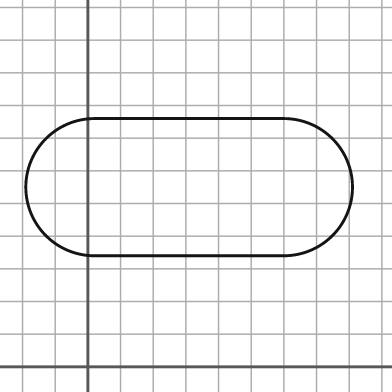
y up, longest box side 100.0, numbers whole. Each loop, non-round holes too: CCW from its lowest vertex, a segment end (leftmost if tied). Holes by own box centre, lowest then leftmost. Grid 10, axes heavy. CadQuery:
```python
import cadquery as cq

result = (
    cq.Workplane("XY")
    .moveTo(2.0, 34.0)
    .lineTo(60.0, 34.0)
    .threePointArc((81.0, 55.0), (60.0, 76.0))
    .lineTo(2.0, 76.0)
    .threePointArc((-19.0, 55.0), (2.0, 34.0))
    .close()
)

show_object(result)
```